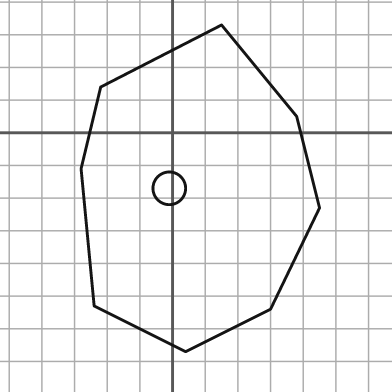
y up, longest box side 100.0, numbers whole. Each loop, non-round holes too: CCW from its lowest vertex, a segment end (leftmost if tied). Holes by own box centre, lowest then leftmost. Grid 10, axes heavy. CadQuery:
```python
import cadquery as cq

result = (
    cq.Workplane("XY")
    .moveTo(4.0, -67.0)
    .lineTo(30.0, -54.0)
    .lineTo(45.0, -23.0)
    .lineTo(38.0, 5.0)
    .lineTo(15.0, 33.0)
    .lineTo(-22.0, 14.0)
    .lineTo(-28.0, -11.0)
    .lineTo(-24.0, -53.0)
    .close()
    .moveTo(-1.0, -17.0)
    .circle(5.0)
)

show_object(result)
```